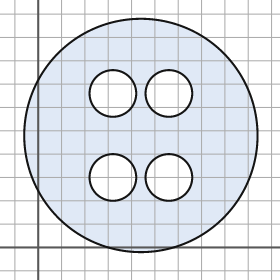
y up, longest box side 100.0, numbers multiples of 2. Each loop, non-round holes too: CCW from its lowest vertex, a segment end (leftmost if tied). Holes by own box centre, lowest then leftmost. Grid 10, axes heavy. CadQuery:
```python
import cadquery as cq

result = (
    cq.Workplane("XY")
    .moveTo(44.0, 48.0)
    .circle(50.0)
    .moveTo(32.0, 30.0)
    .circle(10.0)
    .moveTo(56.0, 30.0)
    .circle(10.0)
    .moveTo(32.0, 66.0)
    .circle(10.0)
    .moveTo(56.0, 66.0)
    .circle(10.0)
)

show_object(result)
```